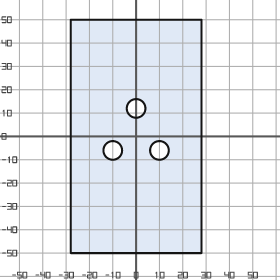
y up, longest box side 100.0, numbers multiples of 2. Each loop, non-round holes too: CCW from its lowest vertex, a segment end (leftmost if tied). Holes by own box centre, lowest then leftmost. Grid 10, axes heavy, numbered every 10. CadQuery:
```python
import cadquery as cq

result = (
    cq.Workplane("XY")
    .moveTo(-28.0, -50.0)
    .lineTo(28.0, -50.0)
    .lineTo(28.0, 50.0)
    .lineTo(-28.0, 50.0)
    .close()
    .moveTo(-10.0, -6.0)
    .circle(4.0)
    .moveTo(10.0, -6.0)
    .circle(4.0)
    .moveTo(0.0, 12.0)
    .circle(4.0)
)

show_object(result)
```